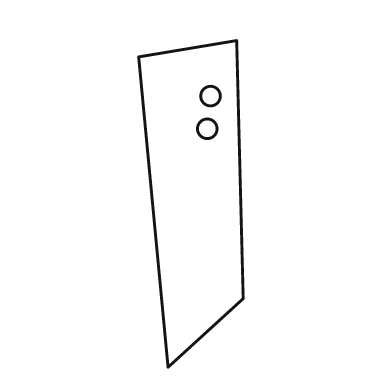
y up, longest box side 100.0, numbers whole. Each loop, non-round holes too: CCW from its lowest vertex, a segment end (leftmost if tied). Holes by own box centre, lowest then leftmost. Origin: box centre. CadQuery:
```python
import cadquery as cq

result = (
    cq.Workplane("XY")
    .moveTo(-7.0, -50.0)
    .lineTo(16.0, -29.0)
    .lineTo(14.0, 50.0)
    .lineTo(-16.0, 45.0)
    .close()
    .moveTo(5.0, 23.0)
    .circle(3.0)
    .moveTo(6.0, 33.0)
    .circle(3.0)
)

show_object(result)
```